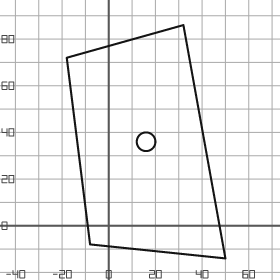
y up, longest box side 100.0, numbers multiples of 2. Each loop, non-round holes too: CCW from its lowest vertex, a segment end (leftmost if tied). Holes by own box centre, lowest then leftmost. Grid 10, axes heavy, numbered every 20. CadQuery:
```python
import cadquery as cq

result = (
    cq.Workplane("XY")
    .moveTo(50.0, -14.0)
    .lineTo(32.0, 86.0)
    .lineTo(-18.0, 72.0)
    .lineTo(-8.0, -8.0)
    .close()
    .moveTo(16.0, 36.0)
    .circle(4.0)
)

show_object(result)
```